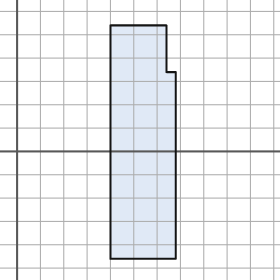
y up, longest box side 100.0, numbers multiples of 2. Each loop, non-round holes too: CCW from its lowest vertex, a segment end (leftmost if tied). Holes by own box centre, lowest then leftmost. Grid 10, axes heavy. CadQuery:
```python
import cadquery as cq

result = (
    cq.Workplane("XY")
    .moveTo(40.0, -46.0)
    .lineTo(68.0, -46.0)
    .lineTo(68.0, 34.0)
    .lineTo(64.0, 34.0)
    .lineTo(64.0, 54.0)
    .lineTo(40.0, 54.0)
    .close()
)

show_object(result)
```